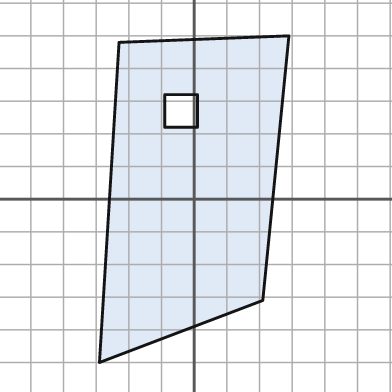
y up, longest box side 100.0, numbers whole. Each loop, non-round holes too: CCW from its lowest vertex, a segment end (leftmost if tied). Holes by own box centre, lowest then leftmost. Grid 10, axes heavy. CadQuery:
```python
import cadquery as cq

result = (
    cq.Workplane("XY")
    .moveTo(-29.0, -50.0)
    .lineTo(21.0, -31.0)
    .lineTo(29.0, 50.0)
    .lineTo(-23.0, 48.0)
    .close()
    .moveTo(-9.0, 22.0)
    .lineTo(1.0, 22.0)
    .lineTo(1.0, 32.0)
    .lineTo(-9.0, 32.0)
    .close()
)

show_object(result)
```